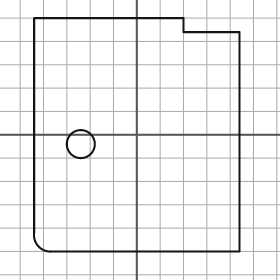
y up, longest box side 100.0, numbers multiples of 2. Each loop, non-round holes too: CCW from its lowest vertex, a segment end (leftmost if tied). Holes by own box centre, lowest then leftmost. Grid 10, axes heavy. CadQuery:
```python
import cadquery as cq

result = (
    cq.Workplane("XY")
    .moveTo(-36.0, -50.0)
    .lineTo(44.0, -50.0)
    .lineTo(44.0, 44.0)
    .lineTo(20.0, 44.0)
    .lineTo(20.0, 50.0)
    .lineTo(-44.0, 50.0)
    .lineTo(-44.0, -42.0)
    .threePointArc((-42.0, -48.0), (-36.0, -50.0))
    .close()
    .moveTo(-24.0, -4.0)
    .circle(6.0)
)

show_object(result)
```